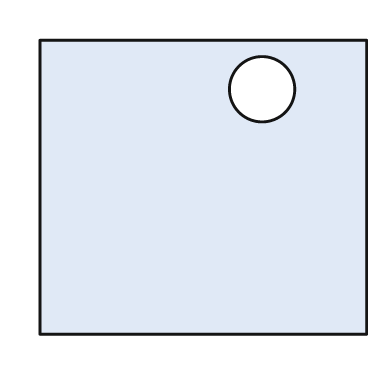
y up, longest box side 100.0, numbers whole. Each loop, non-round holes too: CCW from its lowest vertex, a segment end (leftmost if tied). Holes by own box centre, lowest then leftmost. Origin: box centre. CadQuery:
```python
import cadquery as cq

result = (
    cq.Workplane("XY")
    .moveTo(-50.0, -45.0)
    .lineTo(50.0, -45.0)
    .lineTo(50.0, 45.0)
    .lineTo(-50.0, 45.0)
    .close()
    .moveTo(18.0, 30.0)
    .circle(10.0)
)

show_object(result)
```